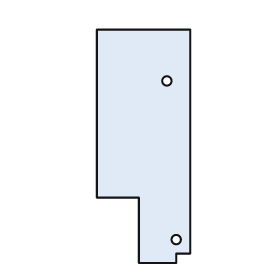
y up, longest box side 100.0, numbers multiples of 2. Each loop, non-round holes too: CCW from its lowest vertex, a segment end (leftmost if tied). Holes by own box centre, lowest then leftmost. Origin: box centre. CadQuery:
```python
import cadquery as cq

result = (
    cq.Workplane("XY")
    .moveTo(-2.0, -50.0)
    .lineTo(14.0, -50.0)
    .lineTo(14.0, -46.0)
    .lineTo(20.0, -46.0)
    .lineTo(20.0, 50.0)
    .lineTo(-20.0, 50.0)
    .lineTo(-20.0, -22.0)
    .lineTo(-2.0, -22.0)
    .close()
    .moveTo(14.0, -40.0)
    .circle(2.0)
    .moveTo(10.0, 28.0)
    .circle(2.0)
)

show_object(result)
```